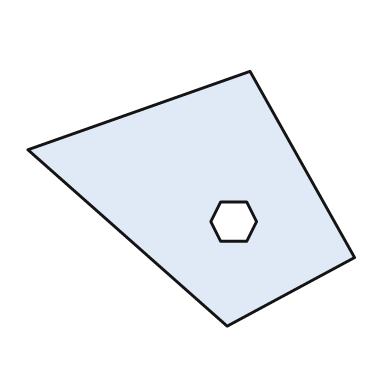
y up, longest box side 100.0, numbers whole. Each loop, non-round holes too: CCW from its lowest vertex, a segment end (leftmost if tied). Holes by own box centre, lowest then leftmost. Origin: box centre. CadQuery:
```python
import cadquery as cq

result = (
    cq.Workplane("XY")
    .moveTo(11.0, -39.0)
    .lineTo(50.0, -18.0)
    .lineTo(18.0, 39.0)
    .lineTo(-50.0, 15.0)
    .close()
    .moveTo(9.0, -13.0)
    .lineTo(17.0, -13.0)
    .lineTo(20.0, -7.0)
    .lineTo(17.0, -1.0)
    .lineTo(9.0, -1.0)
    .lineTo(6.0, -7.0)
    .close()
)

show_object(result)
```